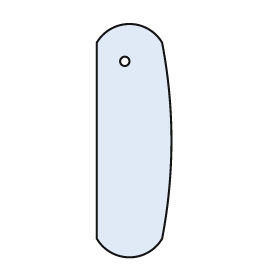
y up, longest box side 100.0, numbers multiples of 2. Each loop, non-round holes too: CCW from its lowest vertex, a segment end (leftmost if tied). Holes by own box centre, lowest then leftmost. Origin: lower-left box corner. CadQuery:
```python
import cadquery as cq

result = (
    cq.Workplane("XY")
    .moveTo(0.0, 8.0)
    .threePointArc((14.0, 0.0), (28.0, 8.0))
    .threePointArc((32.0, 50.0), (28.0, 92.0))
    .threePointArc((14.0, 100.0), (0.0, 92.0))
    .close()
    .moveTo(12.0, 84.0)
    .circle(2.0)
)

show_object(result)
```